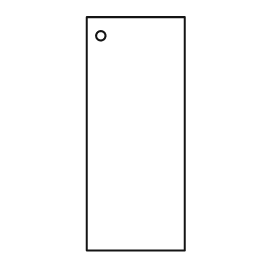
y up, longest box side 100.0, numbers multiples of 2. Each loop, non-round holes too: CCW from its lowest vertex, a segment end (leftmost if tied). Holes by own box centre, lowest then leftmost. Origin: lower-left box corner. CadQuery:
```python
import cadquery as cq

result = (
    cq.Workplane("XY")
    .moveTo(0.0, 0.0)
    .lineTo(42.0, 0.0)
    .lineTo(42.0, 100.0)
    .lineTo(0.0, 100.0)
    .close()
    .moveTo(6.0, 92.0)
    .circle(2.0)
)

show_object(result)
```